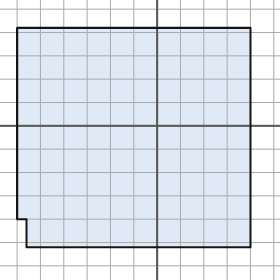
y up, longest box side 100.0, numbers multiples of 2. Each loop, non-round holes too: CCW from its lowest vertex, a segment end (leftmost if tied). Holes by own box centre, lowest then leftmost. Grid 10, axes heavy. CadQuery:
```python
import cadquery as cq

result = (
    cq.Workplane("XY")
    .moveTo(-56.0, -52.0)
    .lineTo(40.0, -52.0)
    .lineTo(40.0, 42.0)
    .lineTo(-60.0, 42.0)
    .lineTo(-60.0, -40.0)
    .lineTo(-56.0, -40.0)
    .close()
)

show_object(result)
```